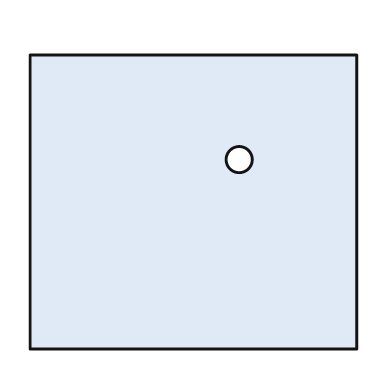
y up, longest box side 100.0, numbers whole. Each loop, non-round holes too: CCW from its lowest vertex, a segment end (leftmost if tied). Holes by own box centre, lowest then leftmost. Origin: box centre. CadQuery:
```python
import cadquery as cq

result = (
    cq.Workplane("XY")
    .moveTo(-50.0, -45.0)
    .lineTo(50.0, -45.0)
    .lineTo(50.0, 45.0)
    .lineTo(-50.0, 45.0)
    .close()
    .moveTo(14.0, 13.0)
    .circle(4.0)
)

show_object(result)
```